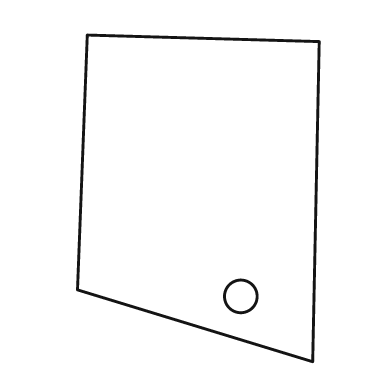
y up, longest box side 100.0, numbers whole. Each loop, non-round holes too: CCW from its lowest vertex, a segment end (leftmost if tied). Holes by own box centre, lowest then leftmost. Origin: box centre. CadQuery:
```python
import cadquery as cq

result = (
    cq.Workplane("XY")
    .moveTo(35.0, -50.0)
    .lineTo(37.0, 48.0)
    .lineTo(-34.0, 50.0)
    .lineTo(-37.0, -28.0)
    .close()
    .moveTo(13.0, -30.0)
    .circle(5.0)
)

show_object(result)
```